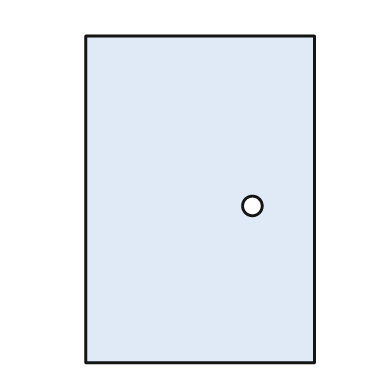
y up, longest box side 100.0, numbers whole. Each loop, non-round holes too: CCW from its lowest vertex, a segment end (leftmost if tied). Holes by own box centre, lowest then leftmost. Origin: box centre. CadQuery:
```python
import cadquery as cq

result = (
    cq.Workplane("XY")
    .moveTo(-35.0, -50.0)
    .lineTo(35.0, -50.0)
    .lineTo(35.0, 50.0)
    .lineTo(-35.0, 50.0)
    .close()
    .moveTo(16.0, -2.0)
    .circle(3.0)
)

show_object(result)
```